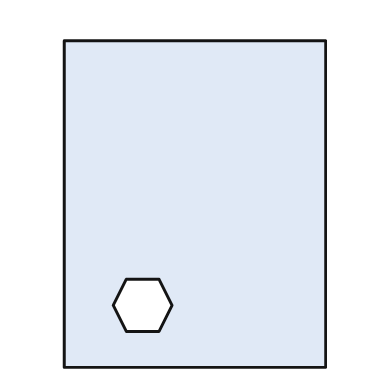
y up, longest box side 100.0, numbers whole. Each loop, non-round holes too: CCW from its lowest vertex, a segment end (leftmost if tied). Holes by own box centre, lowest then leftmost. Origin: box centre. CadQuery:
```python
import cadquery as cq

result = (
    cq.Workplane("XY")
    .moveTo(-40.0, -50.0)
    .lineTo(40.0, -50.0)
    .lineTo(40.0, 50.0)
    .lineTo(-40.0, 50.0)
    .close()
    .moveTo(-21.0, -39.0)
    .lineTo(-11.0, -39.0)
    .lineTo(-7.0, -31.0)
    .lineTo(-11.0, -23.0)
    .lineTo(-21.0, -23.0)
    .lineTo(-25.0, -31.0)
    .close()
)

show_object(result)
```